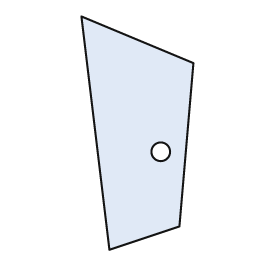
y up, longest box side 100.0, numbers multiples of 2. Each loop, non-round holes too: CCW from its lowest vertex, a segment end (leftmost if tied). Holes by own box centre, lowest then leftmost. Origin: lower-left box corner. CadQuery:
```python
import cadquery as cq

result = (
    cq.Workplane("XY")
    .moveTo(12.0, 0.0)
    .lineTo(42.0, 10.0)
    .lineTo(48.0, 80.0)
    .lineTo(0.0, 100.0)
    .close()
    .moveTo(34.0, 42.0)
    .circle(4.0)
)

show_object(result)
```